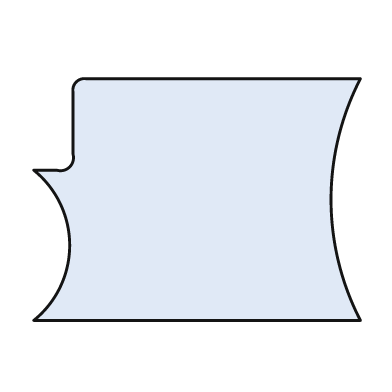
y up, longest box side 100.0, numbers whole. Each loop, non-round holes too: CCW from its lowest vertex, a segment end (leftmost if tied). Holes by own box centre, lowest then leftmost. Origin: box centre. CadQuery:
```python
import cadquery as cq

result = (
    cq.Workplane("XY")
    .moveTo(-50.0, -37.0)
    .lineTo(50.0, -37.0)
    .threePointArc((41.0, 0.0), (50.0, 37.0))
    .lineTo(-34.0, 37.0)
    .threePointArc((-37.0, 36.0), (-38.0, 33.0))
    .lineTo(-38.0, 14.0)
    .threePointArc((-39.0, 10.0), (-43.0, 9.0))
    .lineTo(-50.0, 9.0)
    .threePointArc((-39.0, -14.0), (-50.0, -37.0))
    .close()
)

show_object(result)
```